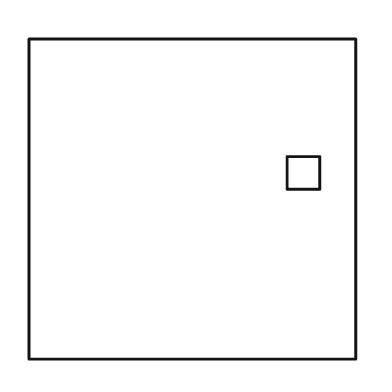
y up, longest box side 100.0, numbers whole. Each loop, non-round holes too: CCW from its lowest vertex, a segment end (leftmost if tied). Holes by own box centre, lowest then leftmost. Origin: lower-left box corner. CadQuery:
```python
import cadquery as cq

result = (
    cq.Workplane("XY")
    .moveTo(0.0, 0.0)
    .lineTo(100.0, 0.0)
    .lineTo(100.0, 98.0)
    .lineTo(0.0, 98.0)
    .close()
    .moveTo(79.0, 52.0)
    .lineTo(89.0, 52.0)
    .lineTo(89.0, 62.0)
    .lineTo(79.0, 62.0)
    .close()
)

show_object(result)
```